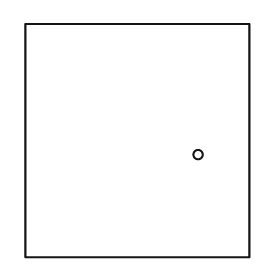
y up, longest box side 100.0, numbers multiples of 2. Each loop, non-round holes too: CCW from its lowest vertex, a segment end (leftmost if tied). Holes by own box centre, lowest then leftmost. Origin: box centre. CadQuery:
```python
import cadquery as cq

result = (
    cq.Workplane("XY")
    .moveTo(-48.0, -50.0)
    .lineTo(48.0, -50.0)
    .lineTo(48.0, 50.0)
    .lineTo(-48.0, 50.0)
    .close()
    .moveTo(26.0, -6.0)
    .circle(2.0)
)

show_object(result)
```